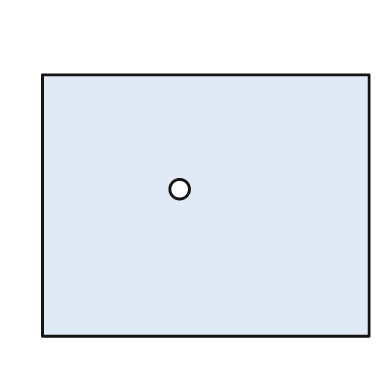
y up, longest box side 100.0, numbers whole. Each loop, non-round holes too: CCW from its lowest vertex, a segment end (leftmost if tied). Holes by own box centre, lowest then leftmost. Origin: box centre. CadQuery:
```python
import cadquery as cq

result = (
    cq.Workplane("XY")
    .moveTo(-50.0, -40.0)
    .lineTo(50.0, -40.0)
    .lineTo(50.0, 40.0)
    .lineTo(-50.0, 40.0)
    .close()
    .moveTo(-8.0, 5.0)
    .circle(3.0)
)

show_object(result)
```